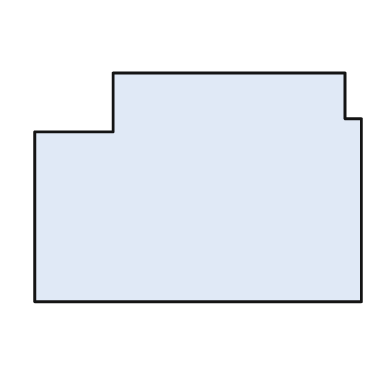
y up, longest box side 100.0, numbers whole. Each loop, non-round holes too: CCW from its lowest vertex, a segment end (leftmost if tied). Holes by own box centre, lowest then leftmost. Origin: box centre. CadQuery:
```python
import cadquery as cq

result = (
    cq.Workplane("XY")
    .moveTo(-50.0, -35.0)
    .lineTo(50.0, -35.0)
    .lineTo(50.0, 21.0)
    .lineTo(45.0, 21.0)
    .lineTo(45.0, 35.0)
    .lineTo(-26.0, 35.0)
    .lineTo(-26.0, 17.0)
    .lineTo(-50.0, 17.0)
    .close()
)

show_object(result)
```